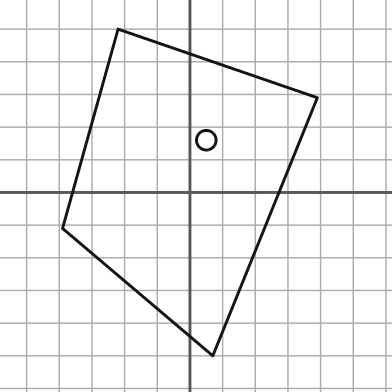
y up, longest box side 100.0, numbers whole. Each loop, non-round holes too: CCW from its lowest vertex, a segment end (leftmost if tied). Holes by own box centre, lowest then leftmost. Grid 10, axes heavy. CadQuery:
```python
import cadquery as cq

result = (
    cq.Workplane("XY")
    .moveTo(7.0, -50.0)
    .lineTo(39.0, 29.0)
    .lineTo(-22.0, 50.0)
    .lineTo(-39.0, -11.0)
    .close()
    .moveTo(5.0, 16.0)
    .circle(3.0)
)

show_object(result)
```